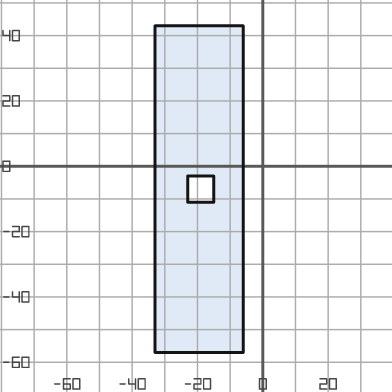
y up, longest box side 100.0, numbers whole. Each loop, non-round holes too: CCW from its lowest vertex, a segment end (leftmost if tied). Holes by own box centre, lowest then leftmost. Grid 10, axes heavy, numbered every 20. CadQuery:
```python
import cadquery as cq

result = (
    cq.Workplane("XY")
    .moveTo(-33.0, -57.0)
    .lineTo(-6.0, -57.0)
    .lineTo(-6.0, 43.0)
    .lineTo(-33.0, 43.0)
    .close()
    .moveTo(-23.0, -11.0)
    .lineTo(-15.0, -11.0)
    .lineTo(-15.0, -3.0)
    .lineTo(-23.0, -3.0)
    .close()
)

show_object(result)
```